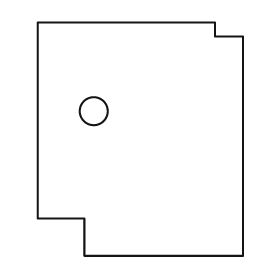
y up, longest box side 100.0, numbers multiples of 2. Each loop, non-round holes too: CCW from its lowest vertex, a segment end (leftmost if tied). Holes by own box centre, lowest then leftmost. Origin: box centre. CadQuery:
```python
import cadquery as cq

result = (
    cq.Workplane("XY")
    .moveTo(-24.0, -50.0)
    .lineTo(44.0, -50.0)
    .lineTo(44.0, 44.0)
    .lineTo(32.0, 44.0)
    .lineTo(32.0, 50.0)
    .lineTo(-44.0, 50.0)
    .lineTo(-44.0, -34.0)
    .lineTo(-24.0, -34.0)
    .close()
    .moveTo(-20.0, 12.0)
    .circle(6.0)
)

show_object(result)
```